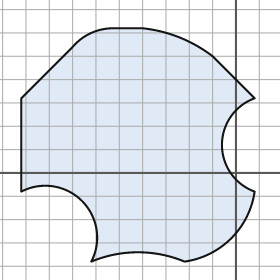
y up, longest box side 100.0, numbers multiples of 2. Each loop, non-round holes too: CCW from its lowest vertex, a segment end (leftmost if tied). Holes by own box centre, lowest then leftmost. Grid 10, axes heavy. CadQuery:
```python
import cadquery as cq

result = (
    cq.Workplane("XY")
    .moveTo(-62.0, -38.0)
    .threePointArc((-42.0, -34.0), (-22.0, -38.0))
    .threePointArc((-2.0, -28.0), (8.0, -8.0))
    .threePointArc((-6.0, 12.0), (8.0, 32.0))
    .lineTo(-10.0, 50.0)
    .threePointArc((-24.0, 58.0), (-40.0, 62.0))
    .lineTo(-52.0, 62.0)
    .threePointArc((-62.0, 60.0), (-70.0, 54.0))
    .lineTo(-92.0, 32.0)
    .lineTo(-92.0, -8.0)
    .threePointArc((-66.0, -12.0), (-62.0, -38.0))
    .close()
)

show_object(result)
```